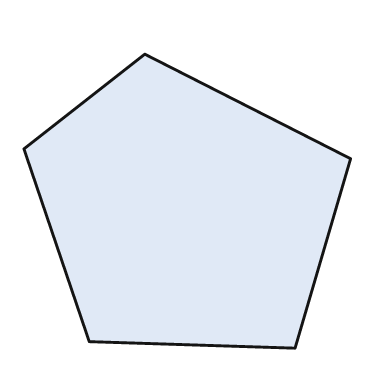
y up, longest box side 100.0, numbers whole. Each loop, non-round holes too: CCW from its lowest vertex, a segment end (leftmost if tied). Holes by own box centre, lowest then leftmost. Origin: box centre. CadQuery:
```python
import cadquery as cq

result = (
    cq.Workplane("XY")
    .moveTo(33.0, -45.0)
    .lineTo(50.0, 13.0)
    .lineTo(-13.0, 45.0)
    .lineTo(-50.0, 16.0)
    .lineTo(-30.0, -43.0)
    .close()
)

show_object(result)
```